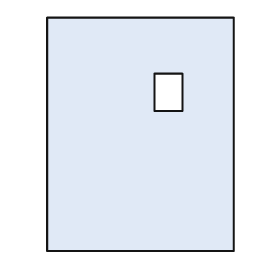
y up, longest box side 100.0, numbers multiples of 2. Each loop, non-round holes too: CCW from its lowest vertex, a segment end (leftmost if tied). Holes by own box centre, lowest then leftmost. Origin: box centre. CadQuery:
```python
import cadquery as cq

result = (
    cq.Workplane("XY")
    .moveTo(-40.0, -50.0)
    .lineTo(40.0, -50.0)
    .lineTo(40.0, 50.0)
    .lineTo(-40.0, 50.0)
    .close()
    .moveTo(6.0, 10.0)
    .lineTo(18.0, 10.0)
    .lineTo(18.0, 26.0)
    .lineTo(6.0, 26.0)
    .close()
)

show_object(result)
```